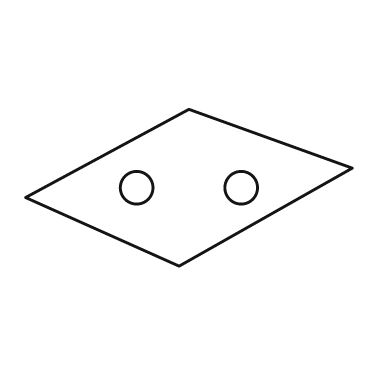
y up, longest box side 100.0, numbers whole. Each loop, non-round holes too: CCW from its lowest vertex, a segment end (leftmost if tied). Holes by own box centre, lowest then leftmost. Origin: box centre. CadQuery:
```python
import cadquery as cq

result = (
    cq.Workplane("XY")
    .moveTo(-3.0, -24.0)
    .lineTo(50.0, 6.0)
    .lineTo(0.0, 24.0)
    .lineTo(-50.0, -3.0)
    .close()
    .moveTo(-16.0, 0.0)
    .circle(5.0)
    .moveTo(16.0, 0.0)
    .circle(5.0)
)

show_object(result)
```